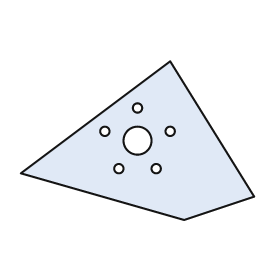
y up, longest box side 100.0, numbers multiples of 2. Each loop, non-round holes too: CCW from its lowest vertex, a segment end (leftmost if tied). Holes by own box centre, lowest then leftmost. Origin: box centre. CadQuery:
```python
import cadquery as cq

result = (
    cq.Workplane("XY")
    .moveTo(20.0, -34.0)
    .lineTo(50.0, -24.0)
    .lineTo(14.0, 34.0)
    .lineTo(-50.0, -14.0)
    .close()
    .moveTo(-8.0, -12.0)
    .circle(2.0)
    .moveTo(8.0, -12.0)
    .circle(2.0)
    .moveTo(0.0, 0.0)
    .circle(6.0)
    .moveTo(-14.0, 4.0)
    .circle(2.0)
    .moveTo(14.0, 4.0)
    .circle(2.0)
    .moveTo(0.0, 14.0)
    .circle(2.0)
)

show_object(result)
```